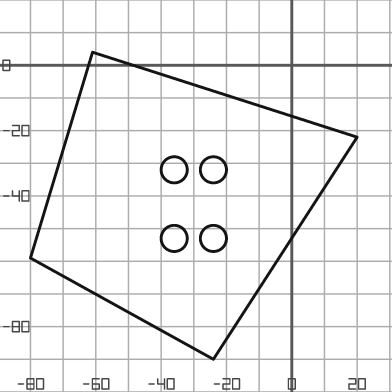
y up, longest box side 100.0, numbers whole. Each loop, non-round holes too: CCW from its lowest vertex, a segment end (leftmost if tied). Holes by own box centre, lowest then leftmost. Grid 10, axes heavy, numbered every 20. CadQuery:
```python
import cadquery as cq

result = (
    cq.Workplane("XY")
    .moveTo(-24.0, -90.0)
    .lineTo(20.0, -22.0)
    .lineTo(-61.0, 4.0)
    .lineTo(-80.0, -59.0)
    .close()
    .moveTo(-36.0, -53.0)
    .circle(4.0)
    .moveTo(-24.0, -53.0)
    .circle(4.0)
    .moveTo(-36.0, -32.0)
    .circle(4.0)
    .moveTo(-24.0, -32.0)
    .circle(4.0)
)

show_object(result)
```